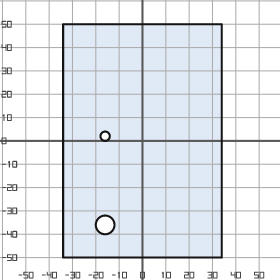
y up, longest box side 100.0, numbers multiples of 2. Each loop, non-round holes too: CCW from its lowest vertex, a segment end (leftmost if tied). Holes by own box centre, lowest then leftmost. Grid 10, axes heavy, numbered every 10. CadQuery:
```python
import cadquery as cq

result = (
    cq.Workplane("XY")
    .moveTo(-34.0, -50.0)
    .lineTo(34.0, -50.0)
    .lineTo(34.0, 50.0)
    .lineTo(-34.0, 50.0)
    .close()
    .moveTo(-16.0, -36.0)
    .circle(4.0)
    .moveTo(-16.0, 2.0)
    .circle(2.0)
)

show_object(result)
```